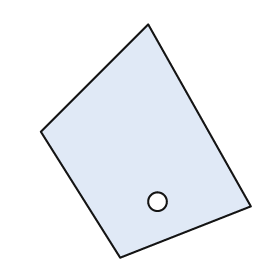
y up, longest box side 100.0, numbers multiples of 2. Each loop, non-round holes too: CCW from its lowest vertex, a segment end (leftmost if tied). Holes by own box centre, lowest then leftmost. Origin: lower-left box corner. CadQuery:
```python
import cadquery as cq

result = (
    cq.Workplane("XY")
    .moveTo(34.0, 0.0)
    .lineTo(90.0, 22.0)
    .lineTo(46.0, 100.0)
    .lineTo(0.0, 54.0)
    .close()
    .moveTo(50.0, 24.0)
    .circle(4.0)
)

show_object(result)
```